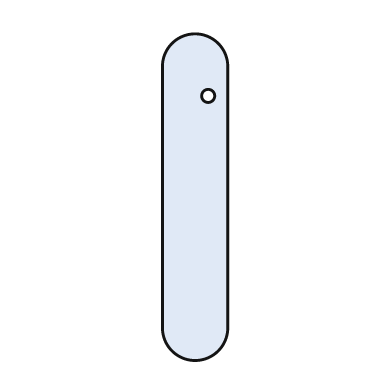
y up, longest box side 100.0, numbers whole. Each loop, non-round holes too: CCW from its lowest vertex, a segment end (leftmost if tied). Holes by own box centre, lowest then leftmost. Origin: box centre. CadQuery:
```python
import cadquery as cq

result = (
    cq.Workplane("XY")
    .moveTo(-10.0, -40.0)
    .threePointArc((0.0, -50.0), (10.0, -40.0))
    .lineTo(10.0, 40.0)
    .threePointArc((0.0, 50.0), (-10.0, 40.0))
    .close()
    .moveTo(4.0, 31.0)
    .circle(2.0)
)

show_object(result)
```